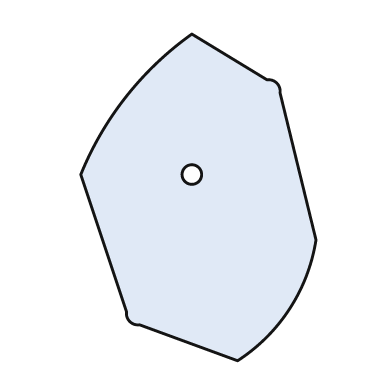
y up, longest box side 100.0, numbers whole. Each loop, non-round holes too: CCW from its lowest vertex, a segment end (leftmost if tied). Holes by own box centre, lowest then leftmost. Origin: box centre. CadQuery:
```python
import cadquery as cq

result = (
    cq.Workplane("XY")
    .moveTo(12.0, -50.0)
    .threePointArc((28.0, -34.0), (36.0, -13.0))
    .lineTo(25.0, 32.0)
    .threePointArc((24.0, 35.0), (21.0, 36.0))
    .lineTo(-2.0, 50.0)
    .threePointArc((-22.0, 31.0), (-36.0, 7.0))
    .lineTo(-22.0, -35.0)
    .threePointArc((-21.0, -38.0), (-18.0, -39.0))
    .close()
    .moveTo(-2.0, 7.0)
    .circle(3.0)
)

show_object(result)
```